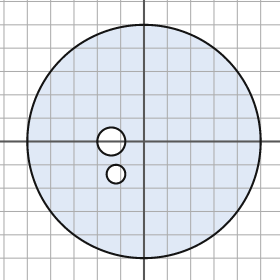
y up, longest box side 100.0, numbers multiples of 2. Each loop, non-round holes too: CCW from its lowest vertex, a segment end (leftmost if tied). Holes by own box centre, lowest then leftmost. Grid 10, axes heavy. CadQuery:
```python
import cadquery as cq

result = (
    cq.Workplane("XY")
    .moveTo(0.0, 0.0)
    .circle(50.0)
    .moveTo(-12.0, -14.0)
    .circle(4.0)
    .moveTo(-14.0, 0.0)
    .circle(6.0)
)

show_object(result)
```